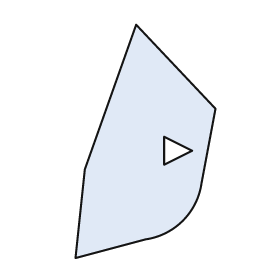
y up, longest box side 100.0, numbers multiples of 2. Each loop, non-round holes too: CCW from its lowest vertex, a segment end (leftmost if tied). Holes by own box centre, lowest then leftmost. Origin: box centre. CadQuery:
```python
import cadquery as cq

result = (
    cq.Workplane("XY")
    .moveTo(-30.0, -50.0)
    .lineTo(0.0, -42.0)
    .threePointArc((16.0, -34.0), (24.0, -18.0))
    .lineTo(30.0, 14.0)
    .lineTo(-4.0, 50.0)
    .lineTo(-26.0, -12.0)
    .close()
    .moveTo(8.0, -10.0)
    .lineTo(20.0, -4.0)
    .lineTo(8.0, 2.0)
    .close()
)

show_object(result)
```